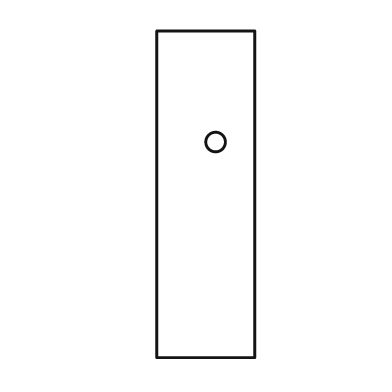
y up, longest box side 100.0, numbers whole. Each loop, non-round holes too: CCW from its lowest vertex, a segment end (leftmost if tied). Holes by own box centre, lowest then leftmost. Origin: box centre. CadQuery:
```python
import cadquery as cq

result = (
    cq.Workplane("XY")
    .moveTo(-15.0, -50.0)
    .lineTo(15.0, -50.0)
    .lineTo(15.0, 50.0)
    .lineTo(-15.0, 50.0)
    .close()
    .moveTo(3.0, 16.0)
    .circle(3.0)
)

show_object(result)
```